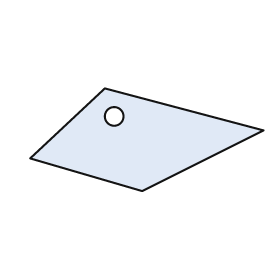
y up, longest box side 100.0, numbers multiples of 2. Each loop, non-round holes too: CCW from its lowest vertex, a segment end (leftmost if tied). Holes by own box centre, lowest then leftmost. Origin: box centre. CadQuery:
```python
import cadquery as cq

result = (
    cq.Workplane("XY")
    .moveTo(-2.0, -22.0)
    .lineTo(50.0, 4.0)
    .lineTo(-18.0, 22.0)
    .lineTo(-50.0, -8.0)
    .close()
    .moveTo(-14.0, 10.0)
    .circle(4.0)
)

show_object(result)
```